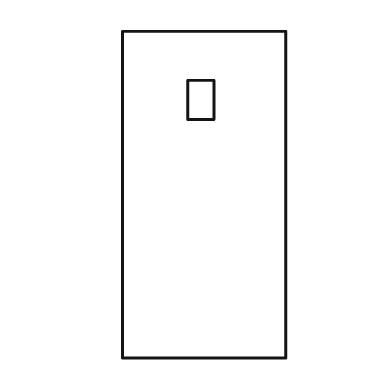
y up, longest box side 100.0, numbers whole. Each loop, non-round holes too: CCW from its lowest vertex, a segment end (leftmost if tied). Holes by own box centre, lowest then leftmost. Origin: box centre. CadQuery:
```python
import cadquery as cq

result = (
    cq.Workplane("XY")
    .moveTo(-25.0, -50.0)
    .lineTo(25.0, -50.0)
    .lineTo(25.0, 50.0)
    .lineTo(-25.0, 50.0)
    .close()
    .moveTo(-5.0, 23.0)
    .lineTo(3.0, 23.0)
    .lineTo(3.0, 35.0)
    .lineTo(-5.0, 35.0)
    .close()
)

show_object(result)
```